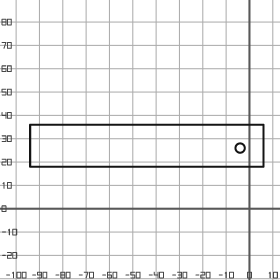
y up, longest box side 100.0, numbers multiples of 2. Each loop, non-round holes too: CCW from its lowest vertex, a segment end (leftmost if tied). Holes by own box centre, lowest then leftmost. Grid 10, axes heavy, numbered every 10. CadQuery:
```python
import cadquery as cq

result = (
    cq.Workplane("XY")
    .moveTo(-94.0, 18.0)
    .lineTo(6.0, 18.0)
    .lineTo(6.0, 36.0)
    .lineTo(-94.0, 36.0)
    .close()
    .moveTo(-4.0, 26.0)
    .circle(2.0)
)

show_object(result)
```